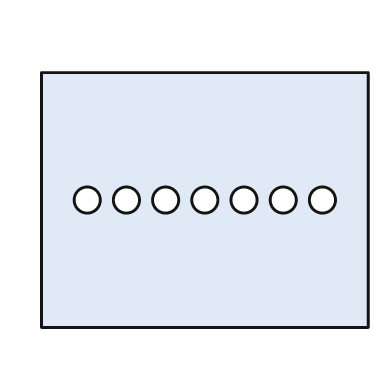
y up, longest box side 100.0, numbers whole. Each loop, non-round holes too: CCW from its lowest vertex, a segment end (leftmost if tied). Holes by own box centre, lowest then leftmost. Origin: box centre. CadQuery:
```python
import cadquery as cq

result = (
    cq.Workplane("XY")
    .moveTo(-50.0, -39.0)
    .lineTo(50.0, -39.0)
    .lineTo(50.0, 39.0)
    .lineTo(-50.0, 39.0)
    .close()
    .moveTo(-36.0, 0.0)
    .circle(4.0)
    .moveTo(-24.0, 0.0)
    .circle(4.0)
    .moveTo(-12.0, 0.0)
    .circle(4.0)
    .moveTo(0.0, 0.0)
    .circle(4.0)
    .moveTo(12.0, 0.0)
    .circle(4.0)
    .moveTo(24.0, 0.0)
    .circle(4.0)
    .moveTo(36.0, 0.0)
    .circle(4.0)
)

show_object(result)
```